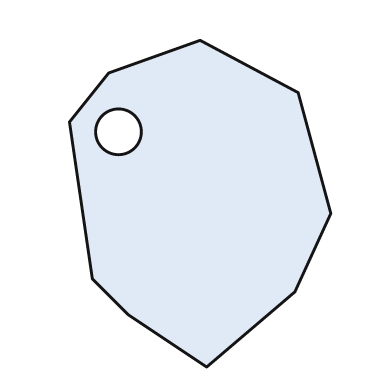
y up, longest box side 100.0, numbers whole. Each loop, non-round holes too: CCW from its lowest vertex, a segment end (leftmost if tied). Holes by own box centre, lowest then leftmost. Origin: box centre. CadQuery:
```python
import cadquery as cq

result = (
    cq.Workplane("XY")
    .moveTo(2.0, -50.0)
    .lineTo(29.0, -27.0)
    .lineTo(40.0, -3.0)
    .lineTo(30.0, 34.0)
    .lineTo(0.0, 50.0)
    .lineTo(-28.0, 40.0)
    .lineTo(-40.0, 25.0)
    .lineTo(-33.0, -23.0)
    .lineTo(-22.0, -34.0)
    .close()
    .moveTo(-25.0, 22.0)
    .circle(7.0)
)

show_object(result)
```